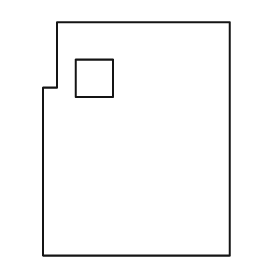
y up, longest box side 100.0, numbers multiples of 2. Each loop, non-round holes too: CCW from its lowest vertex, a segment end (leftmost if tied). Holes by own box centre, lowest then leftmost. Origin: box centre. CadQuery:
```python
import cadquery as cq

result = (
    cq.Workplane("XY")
    .moveTo(-40.0, -50.0)
    .lineTo(40.0, -50.0)
    .lineTo(40.0, 50.0)
    .lineTo(-34.0, 50.0)
    .lineTo(-34.0, 22.0)
    .lineTo(-40.0, 22.0)
    .close()
    .moveTo(-26.0, 18.0)
    .lineTo(-10.0, 18.0)
    .lineTo(-10.0, 34.0)
    .lineTo(-26.0, 34.0)
    .close()
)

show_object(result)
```